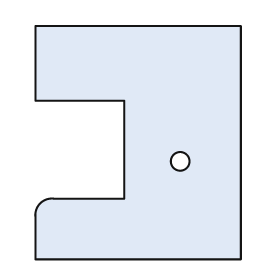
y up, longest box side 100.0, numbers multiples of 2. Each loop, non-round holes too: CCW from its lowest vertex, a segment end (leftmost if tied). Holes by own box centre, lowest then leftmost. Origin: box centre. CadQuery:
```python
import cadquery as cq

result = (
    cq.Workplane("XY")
    .moveTo(-44.0, -50.0)
    .lineTo(44.0, -50.0)
    .lineTo(44.0, 50.0)
    .lineTo(-44.0, 50.0)
    .lineTo(-44.0, 18.0)
    .lineTo(-6.0, 18.0)
    .lineTo(-6.0, -24.0)
    .lineTo(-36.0, -24.0)
    .threePointArc((-42.0, -26.0), (-44.0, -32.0))
    .close()
    .moveTo(18.0, -8.0)
    .circle(4.0)
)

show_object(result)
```